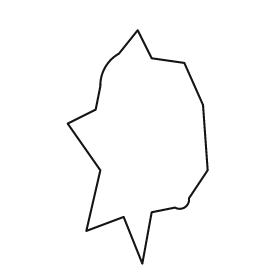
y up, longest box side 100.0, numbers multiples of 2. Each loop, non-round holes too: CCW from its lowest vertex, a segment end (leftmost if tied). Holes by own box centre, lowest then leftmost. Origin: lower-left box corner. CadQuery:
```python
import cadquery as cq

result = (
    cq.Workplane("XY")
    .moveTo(32.0, 0.0)
    .lineTo(36.0, 22.0)
    .lineTo(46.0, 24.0)
    .threePointArc((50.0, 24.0), (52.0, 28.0))
    .lineTo(60.0, 40.0)
    .lineTo(58.0, 68.0)
    .lineTo(50.0, 86.0)
    .lineTo(36.0, 88.0)
    .lineTo(30.0, 100.0)
    .lineTo(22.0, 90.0)
    .threePointArc((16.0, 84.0), (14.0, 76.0))
    .lineTo(12.0, 66.0)
    .lineTo(0.0, 60.0)
    .lineTo(14.0, 40.0)
    .lineTo(8.0, 14.0)
    .lineTo(24.0, 20.0)
    .close()
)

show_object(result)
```